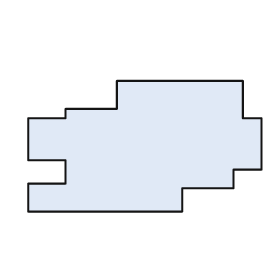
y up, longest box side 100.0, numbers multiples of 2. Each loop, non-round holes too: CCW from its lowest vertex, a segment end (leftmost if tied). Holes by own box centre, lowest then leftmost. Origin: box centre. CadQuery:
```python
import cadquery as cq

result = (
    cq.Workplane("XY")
    .moveTo(-50.0, -28.0)
    .lineTo(16.0, -28.0)
    .lineTo(16.0, -18.0)
    .lineTo(38.0, -18.0)
    .lineTo(38.0, -10.0)
    .lineTo(50.0, -10.0)
    .lineTo(50.0, 12.0)
    .lineTo(42.0, 12.0)
    .lineTo(42.0, 28.0)
    .lineTo(-12.0, 28.0)
    .lineTo(-12.0, 16.0)
    .lineTo(-34.0, 16.0)
    .lineTo(-34.0, 12.0)
    .lineTo(-50.0, 12.0)
    .lineTo(-50.0, -6.0)
    .lineTo(-34.0, -6.0)
    .lineTo(-34.0, -16.0)
    .lineTo(-50.0, -16.0)
    .close()
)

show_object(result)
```